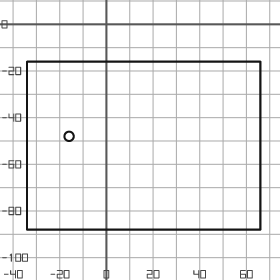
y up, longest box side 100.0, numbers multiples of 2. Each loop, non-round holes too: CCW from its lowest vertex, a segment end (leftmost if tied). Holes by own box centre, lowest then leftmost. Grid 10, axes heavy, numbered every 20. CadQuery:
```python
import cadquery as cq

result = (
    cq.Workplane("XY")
    .moveTo(-34.0, -88.0)
    .lineTo(66.0, -88.0)
    .lineTo(66.0, -16.0)
    .lineTo(-34.0, -16.0)
    .close()
    .moveTo(-16.0, -48.0)
    .circle(2.0)
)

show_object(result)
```